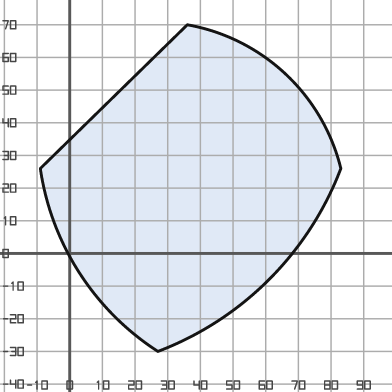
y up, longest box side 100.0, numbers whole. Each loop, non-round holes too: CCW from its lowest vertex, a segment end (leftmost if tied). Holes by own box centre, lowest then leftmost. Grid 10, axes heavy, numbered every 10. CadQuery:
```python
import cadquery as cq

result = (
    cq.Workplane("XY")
    .moveTo(27.0, -30.0)
    .threePointArc((61.0, -8.0), (83.0, 26.0))
    .threePointArc((66.0, 55.0), (36.0, 70.0))
    .lineTo(-9.0, 26.0)
    .threePointArc((3.0, -6.0), (27.0, -30.0))
    .close()
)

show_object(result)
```